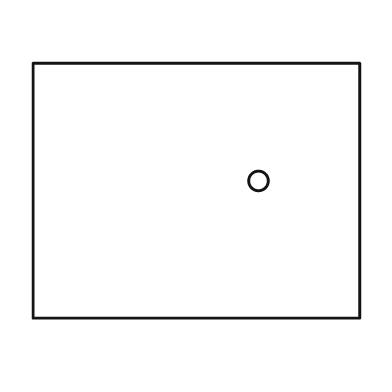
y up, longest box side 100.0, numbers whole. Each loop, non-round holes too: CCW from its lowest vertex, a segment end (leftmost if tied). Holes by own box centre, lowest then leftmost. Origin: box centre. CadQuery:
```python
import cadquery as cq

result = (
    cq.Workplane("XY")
    .moveTo(-50.0, -39.0)
    .lineTo(50.0, -39.0)
    .lineTo(50.0, 39.0)
    .lineTo(-50.0, 39.0)
    .close()
    .moveTo(19.0, 3.0)
    .circle(3.0)
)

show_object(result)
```